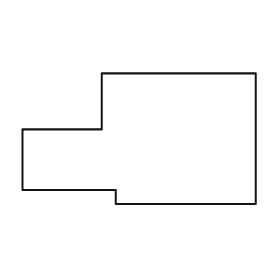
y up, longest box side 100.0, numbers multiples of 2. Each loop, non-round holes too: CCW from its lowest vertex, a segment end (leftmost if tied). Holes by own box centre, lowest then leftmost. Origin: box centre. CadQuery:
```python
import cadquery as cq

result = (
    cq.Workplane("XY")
    .moveTo(-10.0, -28.0)
    .lineTo(50.0, -28.0)
    .lineTo(50.0, 28.0)
    .lineTo(-16.0, 28.0)
    .lineTo(-16.0, 4.0)
    .lineTo(-50.0, 4.0)
    .lineTo(-50.0, -22.0)
    .lineTo(-10.0, -22.0)
    .close()
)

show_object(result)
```